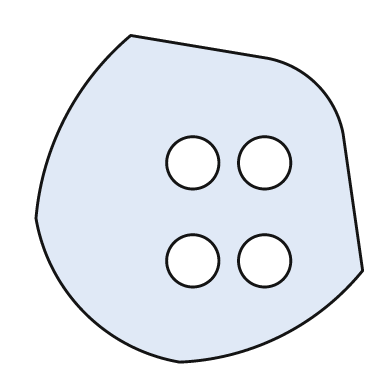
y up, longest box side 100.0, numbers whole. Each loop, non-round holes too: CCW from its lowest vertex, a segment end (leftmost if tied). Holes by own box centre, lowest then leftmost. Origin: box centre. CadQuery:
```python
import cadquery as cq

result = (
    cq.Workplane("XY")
    .moveTo(-6.0, -50.0)
    .threePointArc((25.0, -42.0), (50.0, -22.0))
    .lineTo(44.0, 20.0)
    .threePointArc((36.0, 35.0), (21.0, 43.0))
    .lineTo(-21.0, 50.0)
    .threePointArc((-41.0, 25.0), (-50.0, -6.0))
    .threePointArc((-35.0, -35.0), (-6.0, -50.0))
    .close()
    .moveTo(-2.0, -19.0)
    .circle(8.0)
    .moveTo(20.0, -19.0)
    .circle(8.0)
    .moveTo(-2.0, 11.0)
    .circle(8.0)
    .moveTo(20.0, 11.0)
    .circle(8.0)
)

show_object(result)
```